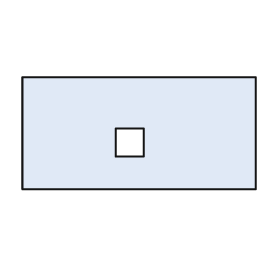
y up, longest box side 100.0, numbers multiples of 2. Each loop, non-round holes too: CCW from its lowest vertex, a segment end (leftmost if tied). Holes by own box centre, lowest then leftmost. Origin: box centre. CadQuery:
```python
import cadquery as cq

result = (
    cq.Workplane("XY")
    .moveTo(-50.0, -24.0)
    .lineTo(50.0, -24.0)
    .lineTo(50.0, 24.0)
    .lineTo(-50.0, 24.0)
    .close()
    .moveTo(-10.0, -10.0)
    .lineTo(2.0, -10.0)
    .lineTo(2.0, 2.0)
    .lineTo(-10.0, 2.0)
    .close()
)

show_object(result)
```